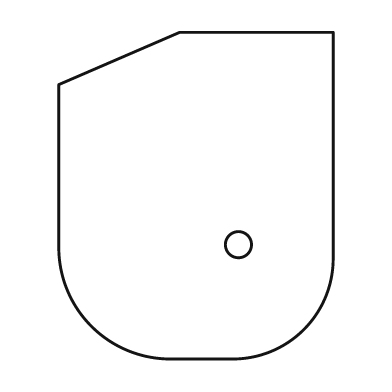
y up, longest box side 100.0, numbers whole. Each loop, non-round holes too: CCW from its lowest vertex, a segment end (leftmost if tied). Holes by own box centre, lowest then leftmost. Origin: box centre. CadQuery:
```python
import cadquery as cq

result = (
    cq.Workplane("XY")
    .moveTo(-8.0, -50.0)
    .lineTo(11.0, -50.0)
    .threePointArc((33.0, -41.0), (42.0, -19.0))
    .lineTo(42.0, 50.0)
    .lineTo(-5.0, 50.0)
    .lineTo(-42.0, 34.0)
    .lineTo(-42.0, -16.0)
    .threePointArc((-32.0, -40.0), (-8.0, -50.0))
    .close()
    .moveTo(13.0, -15.0)
    .circle(4.0)
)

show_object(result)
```